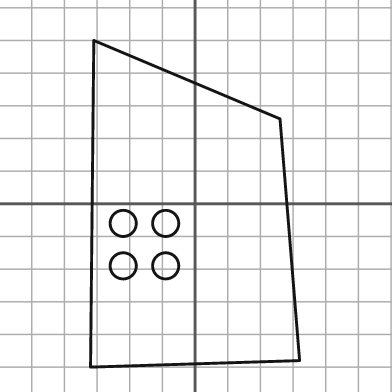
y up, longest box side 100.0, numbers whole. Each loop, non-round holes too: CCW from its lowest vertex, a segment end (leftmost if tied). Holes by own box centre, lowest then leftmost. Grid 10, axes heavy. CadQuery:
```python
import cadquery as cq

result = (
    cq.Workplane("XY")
    .moveTo(-32.0, -50.0)
    .lineTo(32.0, -48.0)
    .lineTo(26.0, 26.0)
    .lineTo(-31.0, 50.0)
    .close()
    .moveTo(-22.0, -19.0)
    .circle(4.0)
    .moveTo(-9.0, -19.0)
    .circle(4.0)
    .moveTo(-22.0, -6.0)
    .circle(4.0)
    .moveTo(-9.0, -6.0)
    .circle(4.0)
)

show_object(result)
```